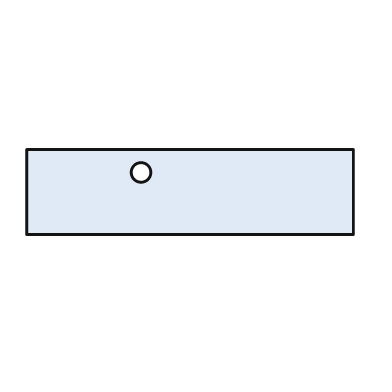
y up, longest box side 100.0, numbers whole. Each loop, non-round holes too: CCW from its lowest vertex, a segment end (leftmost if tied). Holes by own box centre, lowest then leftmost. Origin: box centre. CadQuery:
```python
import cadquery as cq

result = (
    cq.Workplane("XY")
    .moveTo(-50.0, -13.0)
    .lineTo(50.0, -13.0)
    .lineTo(50.0, 13.0)
    .lineTo(-50.0, 13.0)
    .close()
    .moveTo(-15.0, 6.0)
    .circle(3.0)
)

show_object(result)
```